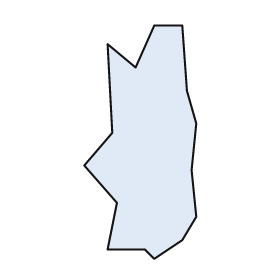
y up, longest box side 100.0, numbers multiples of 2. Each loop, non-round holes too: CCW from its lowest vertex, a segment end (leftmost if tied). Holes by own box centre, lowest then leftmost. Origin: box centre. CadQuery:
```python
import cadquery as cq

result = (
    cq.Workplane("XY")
    .moveTo(6.0, -50.0)
    .lineTo(18.0, -42.0)
    .lineTo(24.0, -32.0)
    .lineTo(22.0, -12.0)
    .lineTo(24.0, 8.0)
    .lineTo(20.0, 22.0)
    .lineTo(18.0, 50.0)
    .lineTo(6.0, 50.0)
    .lineTo(-2.0, 32.0)
    .lineTo(-14.0, 42.0)
    .lineTo(-12.0, 4.0)
    .lineTo(-24.0, -10.0)
    .lineTo(-10.0, -26.0)
    .lineTo(-14.0, -46.0)
    .lineTo(2.0, -46.0)
    .close()
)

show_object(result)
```